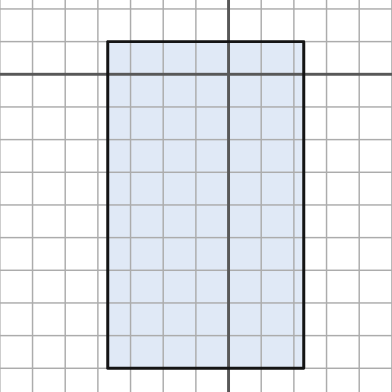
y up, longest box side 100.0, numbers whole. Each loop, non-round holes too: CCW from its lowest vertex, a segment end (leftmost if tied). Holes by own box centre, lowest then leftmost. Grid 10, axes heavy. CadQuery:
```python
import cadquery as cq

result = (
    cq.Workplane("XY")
    .moveTo(-37.0, -90.0)
    .lineTo(23.0, -90.0)
    .lineTo(23.0, 10.0)
    .lineTo(-37.0, 10.0)
    .close()
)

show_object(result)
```